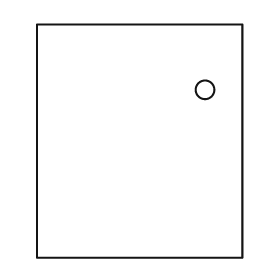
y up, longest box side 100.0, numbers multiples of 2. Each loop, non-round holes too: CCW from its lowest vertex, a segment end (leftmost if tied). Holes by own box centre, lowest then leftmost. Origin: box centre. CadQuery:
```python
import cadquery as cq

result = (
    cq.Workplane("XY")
    .moveTo(-44.0, -50.0)
    .lineTo(44.0, -50.0)
    .lineTo(44.0, 50.0)
    .lineTo(-44.0, 50.0)
    .close()
    .moveTo(28.0, 22.0)
    .circle(4.0)
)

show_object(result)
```